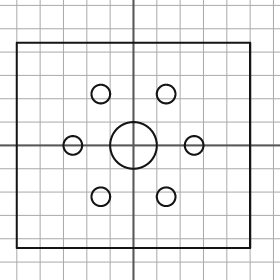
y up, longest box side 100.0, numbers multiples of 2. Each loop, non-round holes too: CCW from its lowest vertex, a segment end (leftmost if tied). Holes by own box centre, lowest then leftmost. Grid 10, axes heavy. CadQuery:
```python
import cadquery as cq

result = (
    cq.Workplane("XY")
    .moveTo(-50.0, -44.0)
    .lineTo(50.0, -44.0)
    .lineTo(50.0, 44.0)
    .lineTo(-50.0, 44.0)
    .close()
    .moveTo(-14.0, -22.0)
    .circle(4.0)
    .moveTo(14.0, -22.0)
    .circle(4.0)
    .moveTo(-26.0, 0.0)
    .circle(4.0)
    .moveTo(0.0, 0.0)
    .circle(10.0)
    .moveTo(26.0, 0.0)
    .circle(4.0)
    .moveTo(-14.0, 22.0)
    .circle(4.0)
    .moveTo(14.0, 22.0)
    .circle(4.0)
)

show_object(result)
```